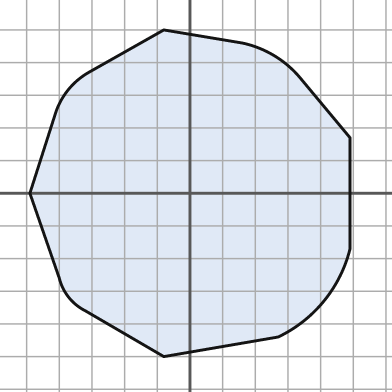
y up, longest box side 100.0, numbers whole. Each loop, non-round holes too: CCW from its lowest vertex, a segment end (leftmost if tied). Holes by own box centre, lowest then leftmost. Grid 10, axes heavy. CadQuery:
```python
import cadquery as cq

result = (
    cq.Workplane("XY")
    .moveTo(-8.0, -50.0)
    .lineTo(27.0, -44.0)
    .threePointArc((41.0, -33.0), (49.0, -17.0))
    .lineTo(49.0, 17.0)
    .lineTo(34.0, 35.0)
    .threePointArc((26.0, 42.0), (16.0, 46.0))
    .lineTo(-8.0, 50.0)
    .lineTo(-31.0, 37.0)
    .threePointArc((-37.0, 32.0), (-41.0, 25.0))
    .lineTo(-49.0, 0.0)
    .lineTo(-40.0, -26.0)
    .threePointArc((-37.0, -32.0), (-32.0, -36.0))
    .close()
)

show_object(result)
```